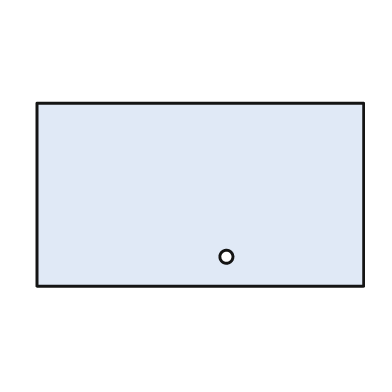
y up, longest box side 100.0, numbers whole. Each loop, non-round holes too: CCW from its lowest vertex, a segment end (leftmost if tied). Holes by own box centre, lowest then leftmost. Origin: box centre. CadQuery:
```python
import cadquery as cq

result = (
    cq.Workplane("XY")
    .moveTo(-50.0, -28.0)
    .lineTo(50.0, -28.0)
    .lineTo(50.0, 28.0)
    .lineTo(-50.0, 28.0)
    .close()
    .moveTo(8.0, -19.0)
    .circle(2.0)
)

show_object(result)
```